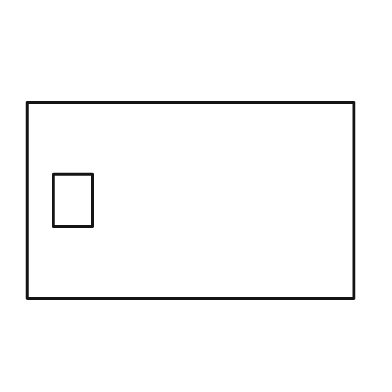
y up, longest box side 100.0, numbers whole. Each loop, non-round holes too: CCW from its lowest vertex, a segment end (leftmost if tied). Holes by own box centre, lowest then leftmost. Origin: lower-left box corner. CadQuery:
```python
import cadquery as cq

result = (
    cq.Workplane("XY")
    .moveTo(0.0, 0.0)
    .lineTo(100.0, 0.0)
    .lineTo(100.0, 60.0)
    .lineTo(0.0, 60.0)
    .close()
    .moveTo(8.0, 22.0)
    .lineTo(20.0, 22.0)
    .lineTo(20.0, 38.0)
    .lineTo(8.0, 38.0)
    .close()
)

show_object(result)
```